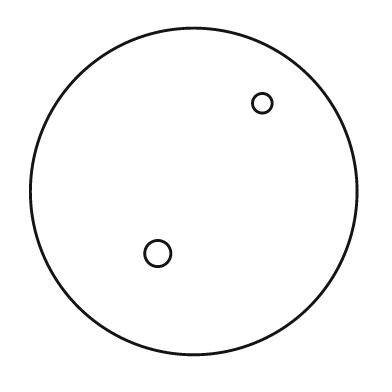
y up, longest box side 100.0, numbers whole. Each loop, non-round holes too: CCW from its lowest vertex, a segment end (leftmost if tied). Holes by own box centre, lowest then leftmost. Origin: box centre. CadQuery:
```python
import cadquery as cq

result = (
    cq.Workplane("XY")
    .moveTo(0.0, 0.0)
    .circle(50.0)
    .moveTo(-11.0, -19.0)
    .circle(4.0)
    .moveTo(21.0, 27.0)
    .circle(3.0)
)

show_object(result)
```